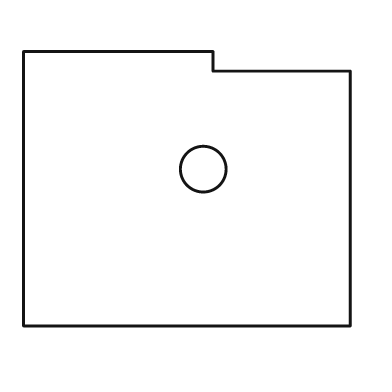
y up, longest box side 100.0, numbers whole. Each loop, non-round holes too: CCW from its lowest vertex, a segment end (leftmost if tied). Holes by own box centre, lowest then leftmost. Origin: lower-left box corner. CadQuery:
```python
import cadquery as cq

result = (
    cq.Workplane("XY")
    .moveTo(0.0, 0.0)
    .lineTo(100.0, 0.0)
    .lineTo(100.0, 78.0)
    .lineTo(58.0, 78.0)
    .lineTo(58.0, 84.0)
    .lineTo(0.0, 84.0)
    .close()
    .moveTo(55.0, 48.0)
    .circle(7.0)
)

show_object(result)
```